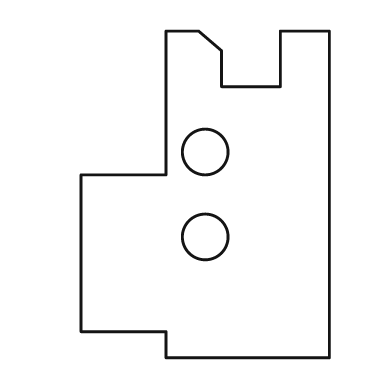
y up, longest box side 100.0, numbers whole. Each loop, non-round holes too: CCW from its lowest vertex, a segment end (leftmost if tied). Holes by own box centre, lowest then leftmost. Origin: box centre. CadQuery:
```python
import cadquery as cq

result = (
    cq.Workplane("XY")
    .moveTo(-12.0, -50.0)
    .lineTo(38.0, -50.0)
    .lineTo(38.0, 50.0)
    .lineTo(23.0, 50.0)
    .lineTo(23.0, 33.0)
    .lineTo(5.0, 33.0)
    .lineTo(5.0, 44.0)
    .lineTo(-2.0, 50.0)
    .lineTo(-12.0, 50.0)
    .lineTo(-12.0, 6.0)
    .lineTo(-38.0, 6.0)
    .lineTo(-38.0, -42.0)
    .lineTo(-12.0, -42.0)
    .close()
    .moveTo(0.0, -13.0)
    .circle(7.0)
    .moveTo(0.0, 13.0)
    .circle(7.0)
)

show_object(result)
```